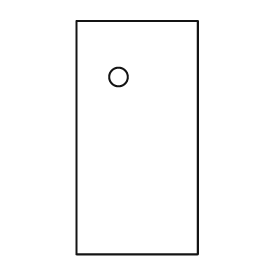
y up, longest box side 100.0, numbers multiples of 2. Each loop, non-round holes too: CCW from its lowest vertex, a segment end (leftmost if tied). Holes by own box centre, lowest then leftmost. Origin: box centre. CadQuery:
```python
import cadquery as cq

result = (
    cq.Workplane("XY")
    .moveTo(-26.0, -50.0)
    .lineTo(26.0, -50.0)
    .lineTo(26.0, 50.0)
    .lineTo(-26.0, 50.0)
    .close()
    .moveTo(-8.0, 26.0)
    .circle(4.0)
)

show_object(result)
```